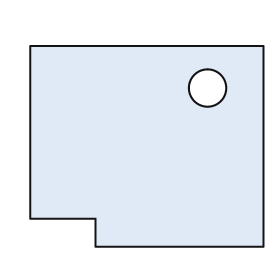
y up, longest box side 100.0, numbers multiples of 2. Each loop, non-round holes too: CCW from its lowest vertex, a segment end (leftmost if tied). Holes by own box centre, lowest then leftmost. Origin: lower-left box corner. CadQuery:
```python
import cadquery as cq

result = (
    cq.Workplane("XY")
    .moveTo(28.0, 0.0)
    .lineTo(100.0, 0.0)
    .lineTo(100.0, 86.0)
    .lineTo(0.0, 86.0)
    .lineTo(0.0, 12.0)
    .lineTo(28.0, 12.0)
    .close()
    .moveTo(76.0, 68.0)
    .circle(8.0)
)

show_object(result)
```